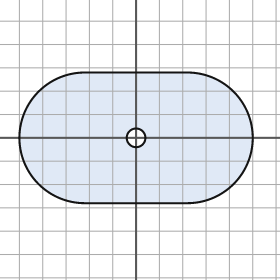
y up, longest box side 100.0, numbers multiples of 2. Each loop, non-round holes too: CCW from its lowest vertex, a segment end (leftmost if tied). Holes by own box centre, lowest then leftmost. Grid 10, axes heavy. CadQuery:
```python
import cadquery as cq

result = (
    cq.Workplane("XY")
    .moveTo(-22.0, -28.0)
    .lineTo(22.0, -28.0)
    .threePointArc((50.0, 0.0), (22.0, 28.0))
    .lineTo(-22.0, 28.0)
    .threePointArc((-50.0, 0.0), (-22.0, -28.0))
    .close()
    .moveTo(0.0, 0.0)
    .circle(4.0)
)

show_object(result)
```